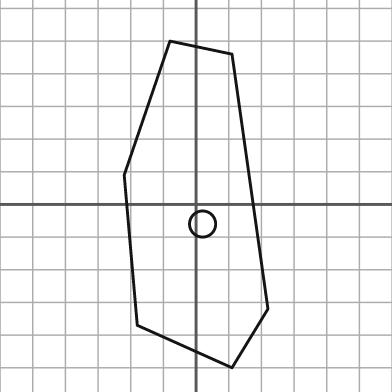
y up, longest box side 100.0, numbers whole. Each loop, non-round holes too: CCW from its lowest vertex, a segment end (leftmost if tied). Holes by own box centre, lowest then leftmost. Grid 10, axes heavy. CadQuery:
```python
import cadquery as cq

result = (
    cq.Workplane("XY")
    .moveTo(11.0, -50.0)
    .lineTo(22.0, -32.0)
    .lineTo(11.0, 46.0)
    .lineTo(-8.0, 50.0)
    .lineTo(-22.0, 9.0)
    .lineTo(-18.0, -37.0)
    .close()
    .moveTo(2.0, -6.0)
    .circle(4.0)
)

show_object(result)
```